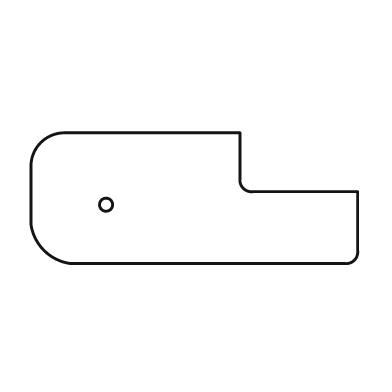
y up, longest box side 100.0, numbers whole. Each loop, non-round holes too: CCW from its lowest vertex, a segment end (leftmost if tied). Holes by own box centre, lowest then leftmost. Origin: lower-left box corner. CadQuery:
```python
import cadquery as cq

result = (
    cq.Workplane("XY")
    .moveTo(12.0, 0.0)
    .lineTo(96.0, 0.0)
    .threePointArc((99.0, 1.0), (100.0, 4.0))
    .lineTo(100.0, 22.0)
    .lineTo(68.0, 22.0)
    .threePointArc((65.0, 23.0), (64.0, 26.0))
    .lineTo(64.0, 40.0)
    .lineTo(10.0, 40.0)
    .threePointArc((3.0, 37.0), (0.0, 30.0))
    .lineTo(0.0, 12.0)
    .threePointArc((4.0, 4.0), (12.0, 0.0))
    .close()
    .moveTo(23.0, 18.0)
    .circle(2.0)
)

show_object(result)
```